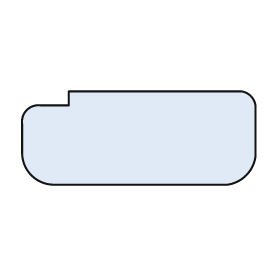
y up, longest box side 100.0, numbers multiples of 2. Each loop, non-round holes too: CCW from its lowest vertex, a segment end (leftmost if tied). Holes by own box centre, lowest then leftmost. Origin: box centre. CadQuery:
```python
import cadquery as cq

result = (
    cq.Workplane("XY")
    .moveTo(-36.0, -20.0)
    .lineTo(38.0, -20.0)
    .threePointArc((46.0, -16.0), (50.0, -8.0))
    .lineTo(50.0, 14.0)
    .threePointArc((48.0, 18.0), (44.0, 20.0))
    .lineTo(-30.0, 20.0)
    .lineTo(-30.0, 14.0)
    .lineTo(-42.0, 14.0)
    .threePointArc((-48.0, 12.0), (-50.0, 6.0))
    .lineTo(-50.0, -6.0)
    .threePointArc((-46.0, -16.0), (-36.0, -20.0))
    .close()
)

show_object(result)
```